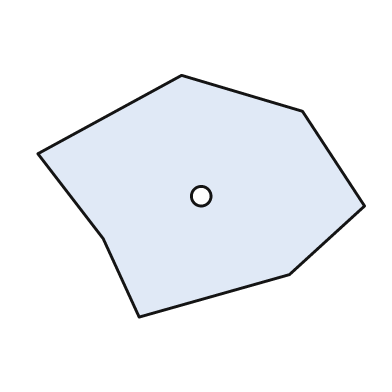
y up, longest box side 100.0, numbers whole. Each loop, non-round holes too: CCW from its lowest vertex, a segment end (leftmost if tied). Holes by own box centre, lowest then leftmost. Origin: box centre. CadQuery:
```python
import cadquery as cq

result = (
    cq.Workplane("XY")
    .moveTo(-19.0, -37.0)
    .lineTo(27.0, -24.0)
    .lineTo(50.0, -3.0)
    .lineTo(31.0, 26.0)
    .lineTo(-6.0, 37.0)
    .lineTo(-50.0, 13.0)
    .lineTo(-30.0, -13.0)
    .close()
    .moveTo(0.0, 0.0)
    .circle(3.0)
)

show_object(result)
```